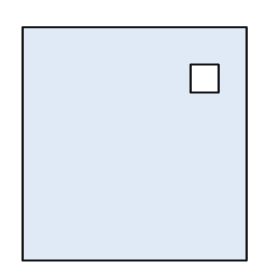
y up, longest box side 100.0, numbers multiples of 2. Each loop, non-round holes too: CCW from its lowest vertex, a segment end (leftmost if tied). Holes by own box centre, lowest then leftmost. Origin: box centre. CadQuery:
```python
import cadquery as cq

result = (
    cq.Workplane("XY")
    .moveTo(-48.0, -50.0)
    .lineTo(48.0, -50.0)
    .lineTo(48.0, 50.0)
    .lineTo(-48.0, 50.0)
    .close()
    .moveTo(24.0, 22.0)
    .lineTo(36.0, 22.0)
    .lineTo(36.0, 34.0)
    .lineTo(24.0, 34.0)
    .close()
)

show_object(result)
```